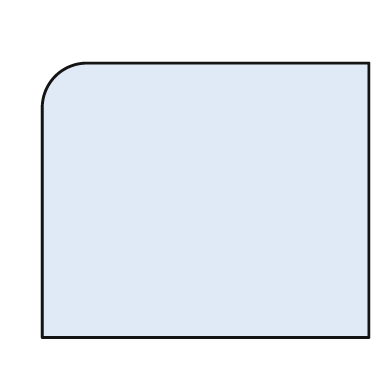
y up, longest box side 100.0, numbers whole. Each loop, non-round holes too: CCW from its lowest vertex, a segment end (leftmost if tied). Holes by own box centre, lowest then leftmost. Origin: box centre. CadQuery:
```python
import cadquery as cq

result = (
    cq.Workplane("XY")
    .moveTo(-50.0, -42.0)
    .lineTo(50.0, -42.0)
    .lineTo(50.0, 42.0)
    .lineTo(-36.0, 42.0)
    .threePointArc((-46.0, 38.0), (-50.0, 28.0))
    .close()
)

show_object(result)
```